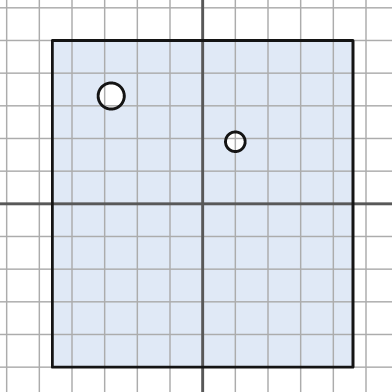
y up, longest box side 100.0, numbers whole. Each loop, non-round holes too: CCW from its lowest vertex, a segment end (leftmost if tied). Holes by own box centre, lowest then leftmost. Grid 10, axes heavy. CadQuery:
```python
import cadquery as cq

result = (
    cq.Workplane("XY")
    .moveTo(-46.0, -50.0)
    .lineTo(46.0, -50.0)
    .lineTo(46.0, 50.0)
    .lineTo(-46.0, 50.0)
    .close()
    .moveTo(10.0, 19.0)
    .circle(3.0)
    .moveTo(-28.0, 33.0)
    .circle(4.0)
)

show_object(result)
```